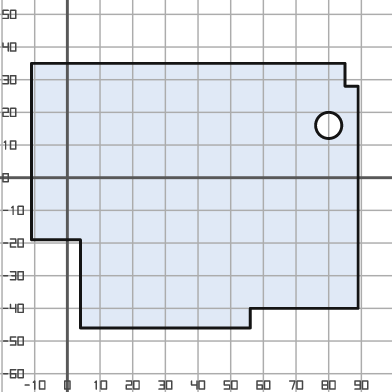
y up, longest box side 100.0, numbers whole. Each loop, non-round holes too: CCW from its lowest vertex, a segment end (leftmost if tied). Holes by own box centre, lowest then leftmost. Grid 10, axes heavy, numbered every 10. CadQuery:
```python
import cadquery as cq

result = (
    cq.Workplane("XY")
    .moveTo(4.0, -46.0)
    .lineTo(56.0, -46.0)
    .lineTo(56.0, -40.0)
    .lineTo(89.0, -40.0)
    .lineTo(89.0, 28.0)
    .lineTo(85.0, 28.0)
    .lineTo(85.0, 35.0)
    .lineTo(-11.0, 35.0)
    .lineTo(-11.0, -19.0)
    .lineTo(4.0, -19.0)
    .close()
    .moveTo(80.0, 16.0)
    .circle(4.0)
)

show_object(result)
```